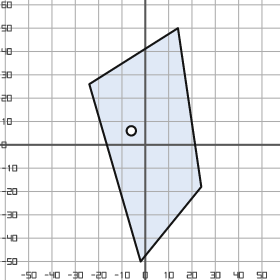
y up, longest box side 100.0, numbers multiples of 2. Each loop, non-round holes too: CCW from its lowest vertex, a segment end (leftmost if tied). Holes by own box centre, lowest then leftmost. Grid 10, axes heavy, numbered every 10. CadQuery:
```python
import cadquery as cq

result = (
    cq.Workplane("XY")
    .moveTo(-2.0, -50.0)
    .lineTo(24.0, -18.0)
    .lineTo(14.0, 50.0)
    .lineTo(-24.0, 26.0)
    .close()
    .moveTo(-6.0, 6.0)
    .circle(2.0)
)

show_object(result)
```